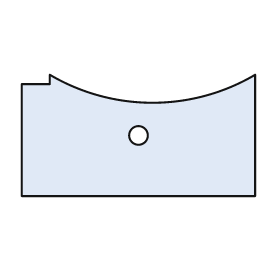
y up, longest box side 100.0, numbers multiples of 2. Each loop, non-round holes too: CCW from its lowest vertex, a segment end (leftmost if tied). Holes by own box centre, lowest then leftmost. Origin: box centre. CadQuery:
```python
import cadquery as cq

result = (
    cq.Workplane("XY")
    .moveTo(-50.0, -26.0)
    .lineTo(50.0, -26.0)
    .lineTo(50.0, 26.0)
    .threePointArc((6.0, 14.0), (-38.0, 26.0))
    .lineTo(-38.0, 22.0)
    .lineTo(-50.0, 22.0)
    .close()
    .moveTo(0.0, 0.0)
    .circle(4.0)
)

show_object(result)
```